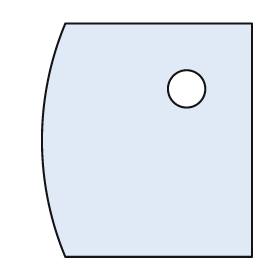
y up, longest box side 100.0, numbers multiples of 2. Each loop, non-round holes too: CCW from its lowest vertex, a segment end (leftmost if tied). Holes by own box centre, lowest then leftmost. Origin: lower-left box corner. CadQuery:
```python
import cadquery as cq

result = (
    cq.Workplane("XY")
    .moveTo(10.0, 0.0)
    .lineTo(90.0, 0.0)
    .lineTo(90.0, 100.0)
    .lineTo(10.0, 100.0)
    .threePointArc((0.0, 50.0), (10.0, 0.0))
    .close()
    .moveTo(62.0, 72.0)
    .circle(8.0)
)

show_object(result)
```